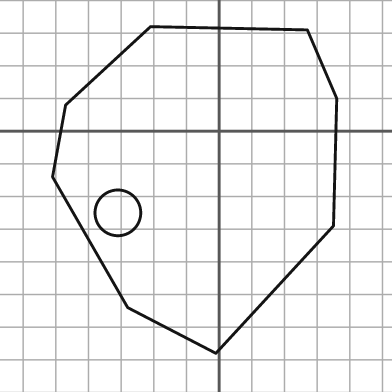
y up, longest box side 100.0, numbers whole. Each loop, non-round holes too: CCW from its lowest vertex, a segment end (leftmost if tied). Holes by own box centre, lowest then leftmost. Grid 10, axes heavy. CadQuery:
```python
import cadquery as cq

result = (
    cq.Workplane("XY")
    .moveTo(-1.0, -68.0)
    .lineTo(35.0, -29.0)
    .lineTo(36.0, 10.0)
    .lineTo(27.0, 31.0)
    .lineTo(-21.0, 32.0)
    .lineTo(-47.0, 8.0)
    .lineTo(-51.0, -14.0)
    .lineTo(-28.0, -54.0)
    .close()
    .moveTo(-31.0, -25.0)
    .circle(7.0)
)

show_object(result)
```